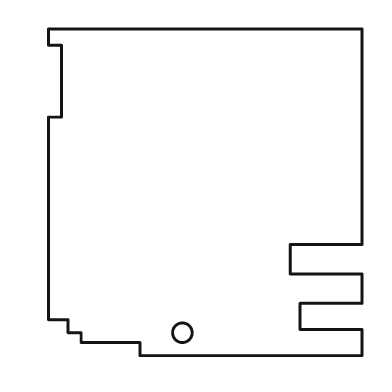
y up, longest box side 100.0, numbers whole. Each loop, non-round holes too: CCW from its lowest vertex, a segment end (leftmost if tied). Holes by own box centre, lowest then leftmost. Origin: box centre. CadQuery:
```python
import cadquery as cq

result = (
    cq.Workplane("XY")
    .moveTo(-20.0, -50.0)
    .lineTo(48.0, -50.0)
    .lineTo(48.0, -42.0)
    .lineTo(29.0, -42.0)
    .lineTo(29.0, -34.0)
    .lineTo(48.0, -34.0)
    .lineTo(48.0, -25.0)
    .lineTo(26.0, -25.0)
    .lineTo(26.0, -16.0)
    .lineTo(48.0, -16.0)
    .lineTo(48.0, 50.0)
    .lineTo(-48.0, 50.0)
    .lineTo(-48.0, 45.0)
    .lineTo(-44.0, 45.0)
    .lineTo(-44.0, 23.0)
    .lineTo(-48.0, 23.0)
    .lineTo(-48.0, -39.0)
    .lineTo(-42.0, -39.0)
    .lineTo(-42.0, -43.0)
    .lineTo(-38.0, -43.0)
    .lineTo(-38.0, -46.0)
    .lineTo(-20.0, -46.0)
    .close()
    .moveTo(-7.0, -43.0)
    .circle(3.0)
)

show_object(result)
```